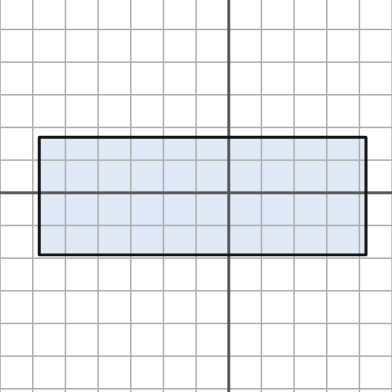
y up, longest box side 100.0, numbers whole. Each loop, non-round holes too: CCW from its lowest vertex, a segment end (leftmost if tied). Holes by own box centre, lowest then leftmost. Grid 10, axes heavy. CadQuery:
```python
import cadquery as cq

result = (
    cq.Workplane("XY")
    .moveTo(-58.0, -19.0)
    .lineTo(42.0, -19.0)
    .lineTo(42.0, 17.0)
    .lineTo(-58.0, 17.0)
    .close()
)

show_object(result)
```